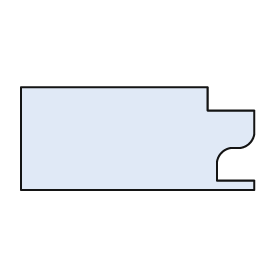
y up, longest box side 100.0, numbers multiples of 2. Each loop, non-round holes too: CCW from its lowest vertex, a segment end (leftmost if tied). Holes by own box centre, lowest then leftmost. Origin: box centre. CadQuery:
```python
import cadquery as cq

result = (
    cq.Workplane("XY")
    .moveTo(-50.0, -22.0)
    .lineTo(50.0, -22.0)
    .lineTo(50.0, -18.0)
    .lineTo(34.0, -18.0)
    .lineTo(34.0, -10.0)
    .threePointArc((36.0, -6.0), (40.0, -4.0))
    .lineTo(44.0, -4.0)
    .threePointArc((48.0, -2.0), (50.0, 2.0))
    .lineTo(50.0, 12.0)
    .lineTo(30.0, 12.0)
    .lineTo(30.0, 22.0)
    .lineTo(-50.0, 22.0)
    .close()
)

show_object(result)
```